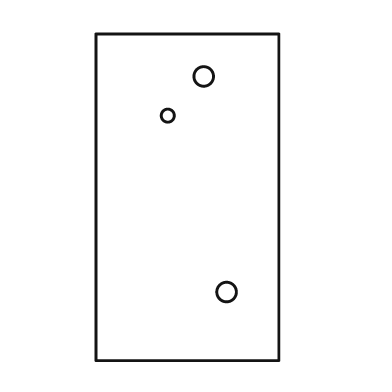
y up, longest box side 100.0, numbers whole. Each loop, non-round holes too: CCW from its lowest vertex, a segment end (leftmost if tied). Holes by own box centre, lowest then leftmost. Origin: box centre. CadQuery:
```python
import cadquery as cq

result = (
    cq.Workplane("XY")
    .moveTo(-28.0, -50.0)
    .lineTo(28.0, -50.0)
    .lineTo(28.0, 50.0)
    .lineTo(-28.0, 50.0)
    .close()
    .moveTo(12.0, -29.0)
    .circle(3.0)
    .moveTo(-6.0, 25.0)
    .circle(2.0)
    .moveTo(5.0, 37.0)
    .circle(3.0)
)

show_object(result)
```